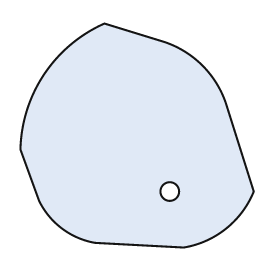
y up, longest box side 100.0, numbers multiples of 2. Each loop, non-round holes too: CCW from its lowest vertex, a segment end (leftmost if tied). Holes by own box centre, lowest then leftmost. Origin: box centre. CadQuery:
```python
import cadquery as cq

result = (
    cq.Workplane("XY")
    .moveTo(20.0, -48.0)
    .threePointArc((38.0, -40.0), (50.0, -24.0))
    .lineTo(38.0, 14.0)
    .threePointArc((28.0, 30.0), (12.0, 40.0))
    .lineTo(-14.0, 48.0)
    .threePointArc((-40.0, 26.0), (-50.0, -6.0))
    .lineTo(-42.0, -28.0)
    .threePointArc((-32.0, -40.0), (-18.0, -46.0))
    .close()
    .moveTo(14.0, -24.0)
    .circle(4.0)
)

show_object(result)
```